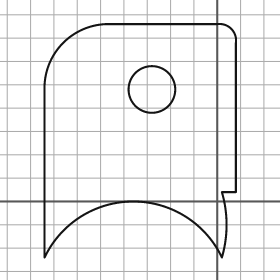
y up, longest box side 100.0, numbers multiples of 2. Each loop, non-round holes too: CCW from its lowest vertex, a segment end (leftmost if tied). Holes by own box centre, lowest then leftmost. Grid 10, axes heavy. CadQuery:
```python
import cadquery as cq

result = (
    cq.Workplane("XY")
    .moveTo(-74.0, -24.0)
    .threePointArc((-36.0, 0.0), (2.0, -24.0))
    .threePointArc((4.0, -10.0), (2.0, 4.0))
    .lineTo(8.0, 4.0)
    .lineTo(8.0, 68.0)
    .threePointArc((6.0, 74.0), (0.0, 76.0))
    .lineTo(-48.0, 76.0)
    .threePointArc((-66.0, 68.0), (-74.0, 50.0))
    .close()
    .moveTo(-28.0, 48.0)
    .circle(10.0)
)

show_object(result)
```